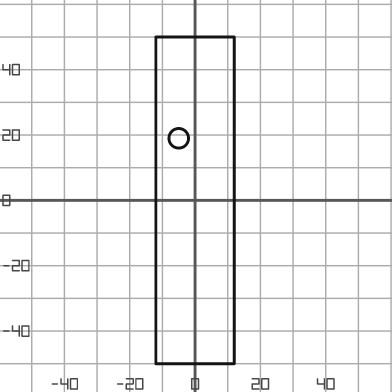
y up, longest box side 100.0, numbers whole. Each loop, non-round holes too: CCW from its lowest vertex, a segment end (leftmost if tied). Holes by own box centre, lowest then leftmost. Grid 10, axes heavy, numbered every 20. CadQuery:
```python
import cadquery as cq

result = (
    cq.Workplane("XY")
    .moveTo(-12.0, -50.0)
    .lineTo(12.0, -50.0)
    .lineTo(12.0, 50.0)
    .lineTo(-12.0, 50.0)
    .close()
    .moveTo(-5.0, 19.0)
    .circle(3.0)
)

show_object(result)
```